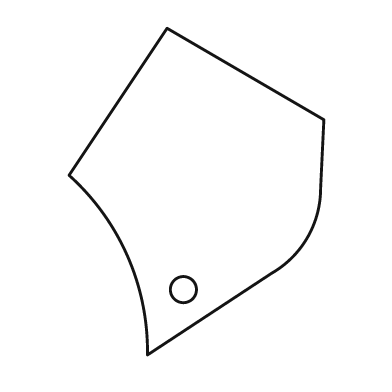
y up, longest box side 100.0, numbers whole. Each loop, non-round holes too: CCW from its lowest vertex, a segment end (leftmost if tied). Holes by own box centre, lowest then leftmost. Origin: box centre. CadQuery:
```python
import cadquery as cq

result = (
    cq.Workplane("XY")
    .moveTo(-15.0, -50.0)
    .lineTo(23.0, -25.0)
    .threePointArc((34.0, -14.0), (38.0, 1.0))
    .lineTo(39.0, 22.0)
    .lineTo(-9.0, 50.0)
    .lineTo(-39.0, 5.0)
    .threePointArc((-21.0, -20.0), (-15.0, -50.0))
    .close()
    .moveTo(-4.0, -30.0)
    .circle(4.0)
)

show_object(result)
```